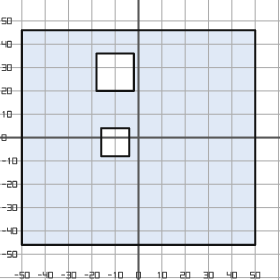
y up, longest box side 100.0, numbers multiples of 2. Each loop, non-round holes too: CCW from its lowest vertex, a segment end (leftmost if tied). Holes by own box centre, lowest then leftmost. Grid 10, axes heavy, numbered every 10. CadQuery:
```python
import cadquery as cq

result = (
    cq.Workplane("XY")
    .moveTo(-50.0, -46.0)
    .lineTo(50.0, -46.0)
    .lineTo(50.0, 46.0)
    .lineTo(-50.0, 46.0)
    .close()
    .moveTo(-16.0, -8.0)
    .lineTo(-4.0, -8.0)
    .lineTo(-4.0, 4.0)
    .lineTo(-16.0, 4.0)
    .close()
    .moveTo(-18.0, 20.0)
    .lineTo(-2.0, 20.0)
    .lineTo(-2.0, 36.0)
    .lineTo(-18.0, 36.0)
    .close()
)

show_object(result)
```